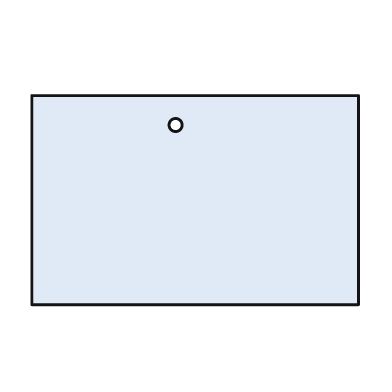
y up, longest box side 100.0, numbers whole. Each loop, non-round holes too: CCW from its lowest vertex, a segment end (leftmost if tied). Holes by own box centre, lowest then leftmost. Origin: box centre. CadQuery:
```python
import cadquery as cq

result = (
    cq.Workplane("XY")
    .moveTo(-50.0, -32.0)
    .lineTo(50.0, -32.0)
    .lineTo(50.0, 32.0)
    .lineTo(-50.0, 32.0)
    .close()
    .moveTo(-6.0, 23.0)
    .circle(2.0)
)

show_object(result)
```